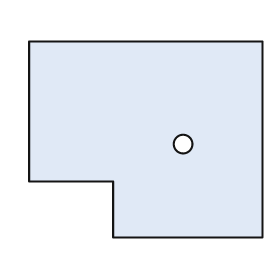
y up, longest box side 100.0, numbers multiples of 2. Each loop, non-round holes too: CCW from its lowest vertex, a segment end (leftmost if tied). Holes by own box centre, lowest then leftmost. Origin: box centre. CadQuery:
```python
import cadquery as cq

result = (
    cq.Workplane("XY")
    .moveTo(-14.0, -42.0)
    .lineTo(50.0, -42.0)
    .lineTo(50.0, 42.0)
    .lineTo(-50.0, 42.0)
    .lineTo(-50.0, -18.0)
    .lineTo(-14.0, -18.0)
    .close()
    .moveTo(16.0, -2.0)
    .circle(4.0)
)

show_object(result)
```